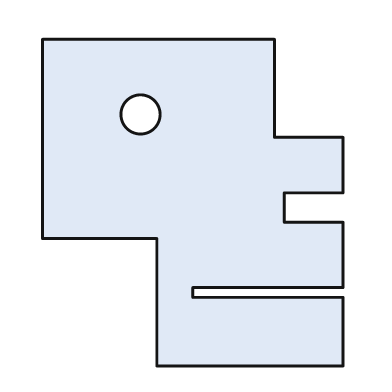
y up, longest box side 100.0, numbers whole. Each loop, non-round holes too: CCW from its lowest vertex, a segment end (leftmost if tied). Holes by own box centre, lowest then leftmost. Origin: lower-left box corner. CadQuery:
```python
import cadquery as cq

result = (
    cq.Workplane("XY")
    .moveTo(35.0, 0.0)
    .lineTo(92.0, 0.0)
    .lineTo(92.0, 21.0)
    .lineTo(46.0, 21.0)
    .lineTo(46.0, 24.0)
    .lineTo(92.0, 24.0)
    .lineTo(92.0, 44.0)
    .lineTo(74.0, 44.0)
    .lineTo(74.0, 53.0)
    .lineTo(92.0, 53.0)
    .lineTo(92.0, 70.0)
    .lineTo(71.0, 70.0)
    .lineTo(71.0, 100.0)
    .lineTo(0.0, 100.0)
    .lineTo(0.0, 39.0)
    .lineTo(35.0, 39.0)
    .close()
    .moveTo(30.0, 77.0)
    .circle(6.0)
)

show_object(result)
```